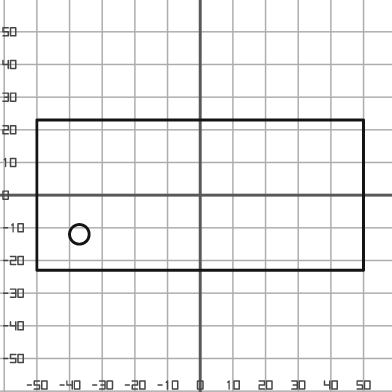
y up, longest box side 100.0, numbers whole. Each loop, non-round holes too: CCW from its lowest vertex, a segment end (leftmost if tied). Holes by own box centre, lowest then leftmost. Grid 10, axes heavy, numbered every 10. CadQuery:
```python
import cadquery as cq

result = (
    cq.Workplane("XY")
    .moveTo(-50.0, -23.0)
    .lineTo(50.0, -23.0)
    .lineTo(50.0, 23.0)
    .lineTo(-50.0, 23.0)
    .close()
    .moveTo(-37.0, -12.0)
    .circle(3.0)
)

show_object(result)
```